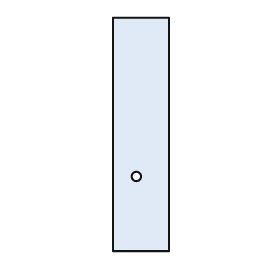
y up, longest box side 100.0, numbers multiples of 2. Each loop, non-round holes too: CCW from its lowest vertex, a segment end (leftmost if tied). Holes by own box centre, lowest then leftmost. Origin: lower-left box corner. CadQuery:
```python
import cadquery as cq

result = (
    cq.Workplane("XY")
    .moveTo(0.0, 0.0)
    .lineTo(24.0, 0.0)
    .lineTo(24.0, 100.0)
    .lineTo(0.0, 100.0)
    .close()
    .moveTo(10.0, 32.0)
    .circle(2.0)
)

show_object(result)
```